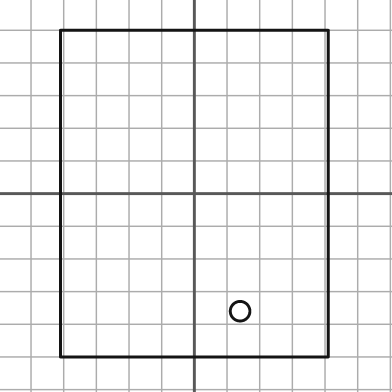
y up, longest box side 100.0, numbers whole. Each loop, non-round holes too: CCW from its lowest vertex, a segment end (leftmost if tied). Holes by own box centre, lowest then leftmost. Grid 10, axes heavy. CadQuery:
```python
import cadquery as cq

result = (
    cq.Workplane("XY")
    .moveTo(-41.0, -50.0)
    .lineTo(41.0, -50.0)
    .lineTo(41.0, 50.0)
    .lineTo(-41.0, 50.0)
    .close()
    .moveTo(14.0, -36.0)
    .circle(3.0)
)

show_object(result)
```